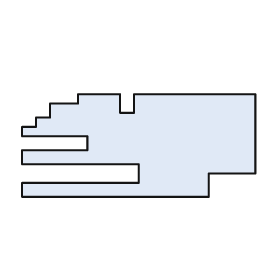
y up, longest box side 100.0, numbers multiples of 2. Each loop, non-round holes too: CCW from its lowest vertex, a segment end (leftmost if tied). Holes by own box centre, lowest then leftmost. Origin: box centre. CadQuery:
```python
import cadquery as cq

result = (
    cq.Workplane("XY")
    .moveTo(-50.0, -22.0)
    .lineTo(30.0, -22.0)
    .lineTo(30.0, -12.0)
    .lineTo(50.0, -12.0)
    .lineTo(50.0, 22.0)
    .lineTo(-2.0, 22.0)
    .lineTo(-2.0, 14.0)
    .lineTo(-8.0, 14.0)
    .lineTo(-8.0, 22.0)
    .lineTo(-26.0, 22.0)
    .lineTo(-26.0, 18.0)
    .lineTo(-38.0, 18.0)
    .lineTo(-38.0, 12.0)
    .lineTo(-44.0, 12.0)
    .lineTo(-44.0, 8.0)
    .lineTo(-50.0, 8.0)
    .lineTo(-50.0, 4.0)
    .lineTo(-22.0, 4.0)
    .lineTo(-22.0, -2.0)
    .lineTo(-50.0, -2.0)
    .lineTo(-50.0, -8.0)
    .lineTo(0.0, -8.0)
    .lineTo(0.0, -16.0)
    .lineTo(-50.0, -16.0)
    .close()
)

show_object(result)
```